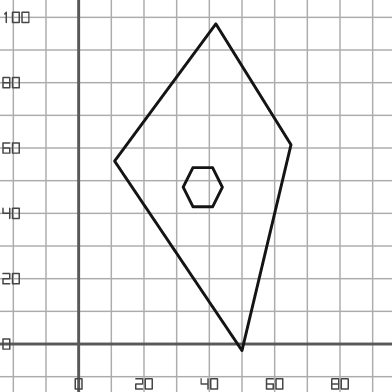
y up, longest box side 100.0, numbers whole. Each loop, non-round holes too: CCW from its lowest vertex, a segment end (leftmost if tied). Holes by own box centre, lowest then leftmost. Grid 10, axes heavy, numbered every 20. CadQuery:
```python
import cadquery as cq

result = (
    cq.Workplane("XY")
    .moveTo(50.0, -2.0)
    .lineTo(65.0, 61.0)
    .lineTo(42.0, 98.0)
    .lineTo(11.0, 56.0)
    .close()
    .moveTo(35.0, 42.0)
    .lineTo(41.0, 42.0)
    .lineTo(44.0, 48.0)
    .lineTo(41.0, 54.0)
    .lineTo(35.0, 54.0)
    .lineTo(32.0, 48.0)
    .close()
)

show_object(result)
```